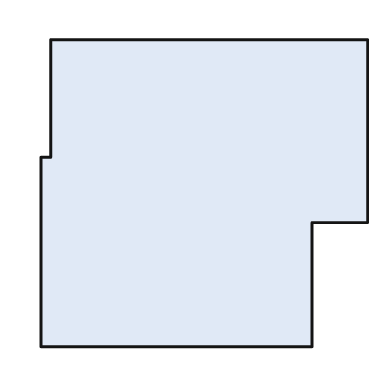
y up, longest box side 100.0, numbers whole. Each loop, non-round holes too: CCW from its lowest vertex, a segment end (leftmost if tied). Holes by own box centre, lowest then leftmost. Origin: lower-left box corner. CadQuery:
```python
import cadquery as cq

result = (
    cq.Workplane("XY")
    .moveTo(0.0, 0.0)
    .lineTo(83.0, 0.0)
    .lineTo(83.0, 38.0)
    .lineTo(100.0, 38.0)
    .lineTo(100.0, 94.0)
    .lineTo(3.0, 94.0)
    .lineTo(3.0, 58.0)
    .lineTo(0.0, 58.0)
    .close()
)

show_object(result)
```